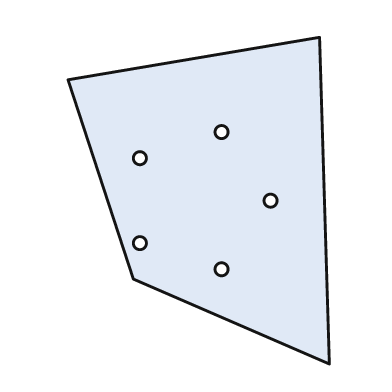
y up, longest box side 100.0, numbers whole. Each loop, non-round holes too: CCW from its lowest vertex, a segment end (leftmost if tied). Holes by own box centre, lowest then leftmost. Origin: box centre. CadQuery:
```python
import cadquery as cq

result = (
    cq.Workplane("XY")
    .moveTo(40.0, -50.0)
    .lineTo(37.0, 50.0)
    .lineTo(-40.0, 37.0)
    .lineTo(-20.0, -24.0)
    .close()
    .moveTo(7.0, -21.0)
    .circle(2.0)
    .moveTo(-18.0, -13.0)
    .circle(2.0)
    .moveTo(22.0, 0.0)
    .circle(2.0)
    .moveTo(-18.0, 13.0)
    .circle(2.0)
    .moveTo(7.0, 21.0)
    .circle(2.0)
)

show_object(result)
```